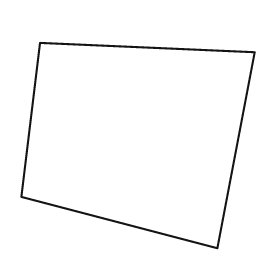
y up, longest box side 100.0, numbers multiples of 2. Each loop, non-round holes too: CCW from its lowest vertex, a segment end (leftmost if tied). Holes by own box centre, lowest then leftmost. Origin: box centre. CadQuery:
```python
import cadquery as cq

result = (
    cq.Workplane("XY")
    .moveTo(34.0, -44.0)
    .lineTo(50.0, 40.0)
    .lineTo(-42.0, 44.0)
    .lineTo(-50.0, -22.0)
    .close()
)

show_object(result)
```